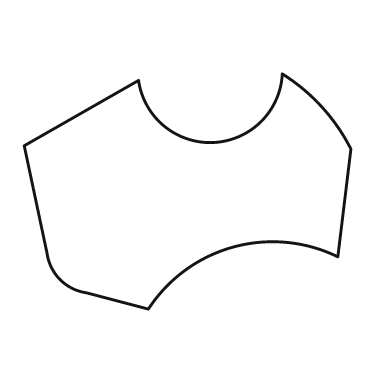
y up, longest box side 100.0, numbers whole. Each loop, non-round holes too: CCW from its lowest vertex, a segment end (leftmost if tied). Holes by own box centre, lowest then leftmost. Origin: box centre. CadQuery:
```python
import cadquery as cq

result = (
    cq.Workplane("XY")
    .moveTo(-12.0, -36.0)
    .threePointArc((14.0, -17.0), (46.0, -20.0))
    .lineTo(50.0, 13.0)
    .threePointArc((41.0, 26.0), (29.0, 36.0))
    .threePointArc((8.0, 15.0), (-15.0, 34.0))
    .lineTo(-50.0, 14.0)
    .lineTo(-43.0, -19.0)
    .threePointArc((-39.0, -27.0), (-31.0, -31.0))
    .close()
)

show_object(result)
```